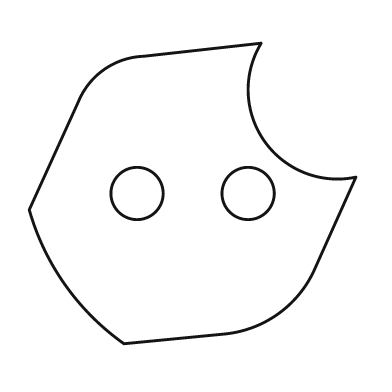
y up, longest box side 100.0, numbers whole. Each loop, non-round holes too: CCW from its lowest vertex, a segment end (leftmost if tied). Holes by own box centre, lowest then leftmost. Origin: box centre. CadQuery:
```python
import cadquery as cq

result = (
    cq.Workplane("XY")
    .moveTo(-21.0, -46.0)
    .lineTo(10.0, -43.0)
    .threePointArc((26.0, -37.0), (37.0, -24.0))
    .lineTo(50.0, 5.0)
    .threePointArc((22.0, 16.0), (21.0, 46.0))
    .lineTo(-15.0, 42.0)
    .threePointArc((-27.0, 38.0), (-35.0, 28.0))
    .lineTo(-50.0, -5.0)
    .threePointArc((-39.0, -28.0), (-21.0, -46.0))
    .close()
    .moveTo(-17.0, 0.0)
    .circle(8.0)
    .moveTo(17.0, 0.0)
    .circle(8.0)
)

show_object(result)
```